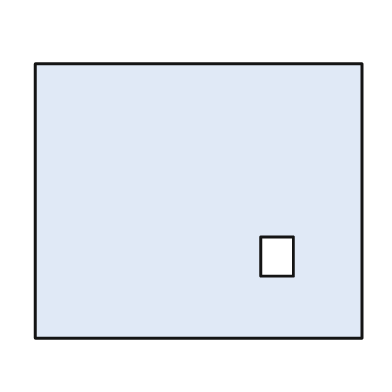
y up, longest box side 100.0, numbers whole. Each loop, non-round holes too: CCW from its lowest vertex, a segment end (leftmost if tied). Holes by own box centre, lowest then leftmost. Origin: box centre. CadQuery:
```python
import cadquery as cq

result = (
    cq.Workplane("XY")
    .moveTo(-50.0, -42.0)
    .lineTo(50.0, -42.0)
    .lineTo(50.0, 42.0)
    .lineTo(-50.0, 42.0)
    .close()
    .moveTo(19.0, -23.0)
    .lineTo(29.0, -23.0)
    .lineTo(29.0, -11.0)
    .lineTo(19.0, -11.0)
    .close()
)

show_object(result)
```